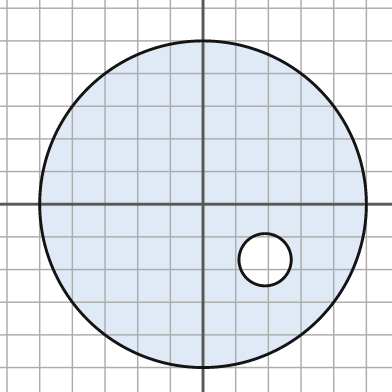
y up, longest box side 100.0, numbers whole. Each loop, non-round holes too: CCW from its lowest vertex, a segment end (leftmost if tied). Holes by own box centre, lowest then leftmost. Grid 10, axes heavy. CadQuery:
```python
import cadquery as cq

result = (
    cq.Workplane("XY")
    .moveTo(0.0, 0.0)
    .circle(50.0)
    .moveTo(19.0, -17.0)
    .circle(8.0)
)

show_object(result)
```